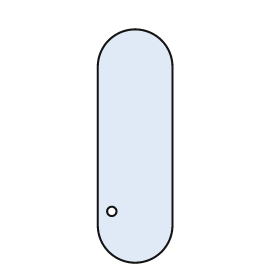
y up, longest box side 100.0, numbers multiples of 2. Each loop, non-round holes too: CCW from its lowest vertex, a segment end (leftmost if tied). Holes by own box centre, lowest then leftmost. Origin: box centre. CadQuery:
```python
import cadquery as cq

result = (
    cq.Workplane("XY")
    .moveTo(-16.0, -34.0)
    .threePointArc((0.0, -50.0), (16.0, -34.0))
    .lineTo(16.0, 34.0)
    .threePointArc((0.0, 50.0), (-16.0, 34.0))
    .close()
    .moveTo(-10.0, -28.0)
    .circle(2.0)
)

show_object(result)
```